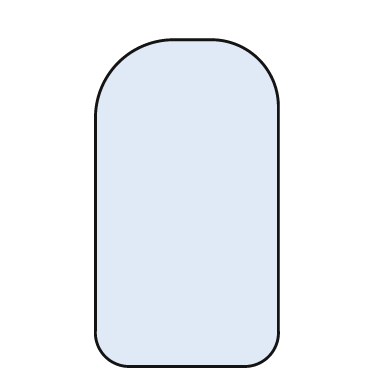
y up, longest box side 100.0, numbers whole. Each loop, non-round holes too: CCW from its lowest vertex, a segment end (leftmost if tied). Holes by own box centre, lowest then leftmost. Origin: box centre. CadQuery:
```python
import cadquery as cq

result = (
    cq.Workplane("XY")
    .moveTo(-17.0, -50.0)
    .lineTo(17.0, -50.0)
    .threePointArc((25.0, -47.0), (28.0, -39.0))
    .lineTo(28.0, 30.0)
    .threePointArc((22.0, 44.0), (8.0, 50.0))
    .lineTo(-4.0, 50.0)
    .threePointArc((-21.0, 43.0), (-28.0, 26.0))
    .lineTo(-28.0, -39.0)
    .threePointArc((-25.0, -47.0), (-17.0, -50.0))
    .close()
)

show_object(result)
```